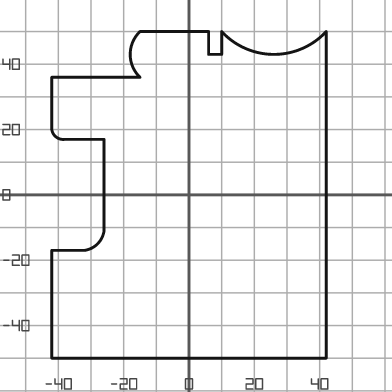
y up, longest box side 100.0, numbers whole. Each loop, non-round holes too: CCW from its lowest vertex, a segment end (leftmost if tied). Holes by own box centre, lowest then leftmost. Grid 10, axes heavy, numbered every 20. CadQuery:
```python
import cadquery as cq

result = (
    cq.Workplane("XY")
    .moveTo(-42.0, -50.0)
    .lineTo(42.0, -50.0)
    .lineTo(42.0, 50.0)
    .threePointArc((26.0, 43.0), (10.0, 50.0))
    .lineTo(10.0, 43.0)
    .lineTo(6.0, 43.0)
    .lineTo(6.0, 50.0)
    .lineTo(-15.0, 50.0)
    .threePointArc((-18.0, 43.0), (-15.0, 36.0))
    .lineTo(-42.0, 36.0)
    .lineTo(-42.0, 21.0)
    .threePointArc((-41.0, 18.0), (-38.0, 17.0))
    .lineTo(-26.0, 17.0)
    .lineTo(-26.0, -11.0)
    .threePointArc((-28.0, -15.0), (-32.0, -17.0))
    .lineTo(-42.0, -17.0)
    .close()
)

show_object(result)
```